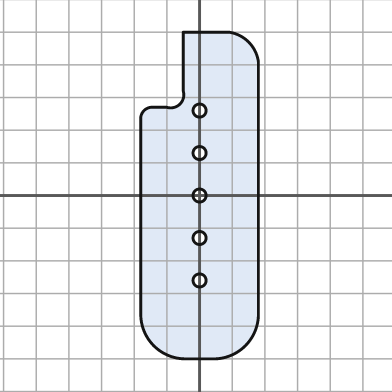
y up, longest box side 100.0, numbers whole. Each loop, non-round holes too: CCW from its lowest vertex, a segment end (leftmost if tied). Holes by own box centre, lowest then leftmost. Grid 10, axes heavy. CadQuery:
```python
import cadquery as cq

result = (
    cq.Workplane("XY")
    .moveTo(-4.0, -50.0)
    .lineTo(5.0, -50.0)
    .threePointArc((14.0, -46.0), (18.0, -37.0))
    .lineTo(18.0, 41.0)
    .threePointArc((15.0, 47.0), (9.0, 50.0))
    .lineTo(-5.0, 50.0)
    .lineTo(-5.0, 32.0)
    .threePointArc((-6.0, 28.0), (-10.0, 27.0))
    .lineTo(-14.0, 27.0)
    .threePointArc((-17.0, 26.0), (-18.0, 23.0))
    .lineTo(-18.0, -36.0)
    .threePointArc((-14.0, -46.0), (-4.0, -50.0))
    .close()
    .moveTo(0.0, -26.0)
    .circle(2.0)
    .moveTo(0.0, -13.0)
    .circle(2.0)
    .moveTo(0.0, 0.0)
    .circle(2.0)
    .moveTo(0.0, 13.0)
    .circle(2.0)
    .moveTo(0.0, 26.0)
    .circle(2.0)
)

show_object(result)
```